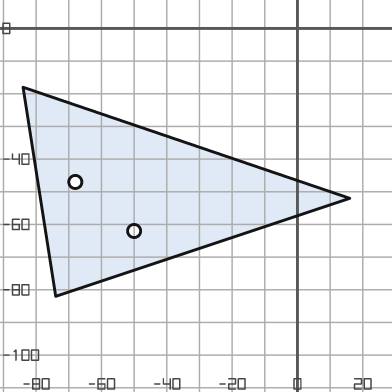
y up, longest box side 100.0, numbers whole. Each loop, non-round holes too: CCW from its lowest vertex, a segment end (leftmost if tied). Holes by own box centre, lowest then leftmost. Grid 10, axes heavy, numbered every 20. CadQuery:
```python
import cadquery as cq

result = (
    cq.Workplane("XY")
    .moveTo(-74.0, -82.0)
    .lineTo(16.0, -52.0)
    .lineTo(-84.0, -18.0)
    .close()
    .moveTo(-50.0, -62.0)
    .circle(2.0)
    .moveTo(-68.0, -47.0)
    .circle(2.0)
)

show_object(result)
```